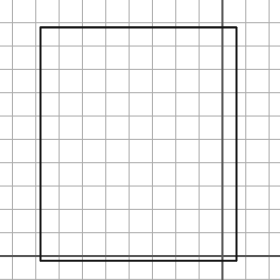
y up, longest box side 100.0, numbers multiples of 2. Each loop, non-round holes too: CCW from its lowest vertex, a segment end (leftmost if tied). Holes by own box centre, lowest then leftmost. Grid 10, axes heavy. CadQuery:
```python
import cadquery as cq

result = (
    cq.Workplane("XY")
    .moveTo(-78.0, -2.0)
    .lineTo(6.0, -2.0)
    .lineTo(6.0, 98.0)
    .lineTo(-78.0, 98.0)
    .close()
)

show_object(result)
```